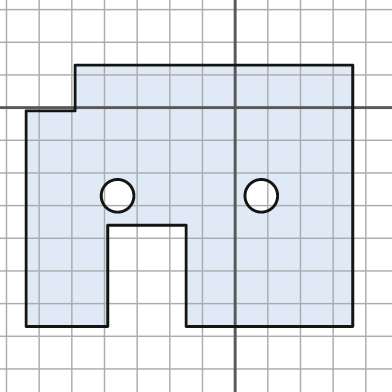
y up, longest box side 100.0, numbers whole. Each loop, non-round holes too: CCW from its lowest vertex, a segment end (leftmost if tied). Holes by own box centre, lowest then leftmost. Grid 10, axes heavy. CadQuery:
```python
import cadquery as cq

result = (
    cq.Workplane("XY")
    .moveTo(-64.0, -67.0)
    .lineTo(-39.0, -67.0)
    .lineTo(-39.0, -36.0)
    .lineTo(-15.0, -36.0)
    .lineTo(-15.0, -67.0)
    .lineTo(36.0, -67.0)
    .lineTo(36.0, 13.0)
    .lineTo(-49.0, 13.0)
    .lineTo(-49.0, -1.0)
    .lineTo(-64.0, -1.0)
    .close()
    .moveTo(-36.0, -27.0)
    .circle(5.0)
    .moveTo(8.0, -27.0)
    .circle(5.0)
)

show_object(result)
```